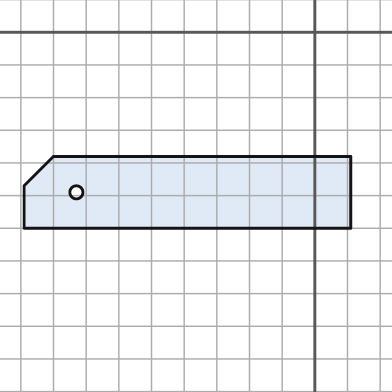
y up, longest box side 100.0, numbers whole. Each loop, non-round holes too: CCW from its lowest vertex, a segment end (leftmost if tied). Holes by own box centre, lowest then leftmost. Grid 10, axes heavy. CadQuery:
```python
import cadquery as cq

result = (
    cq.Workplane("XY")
    .moveTo(-89.0, -60.0)
    .lineTo(11.0, -60.0)
    .lineTo(11.0, -38.0)
    .lineTo(-80.0, -38.0)
    .lineTo(-89.0, -47.0)
    .close()
    .moveTo(-73.0, -49.0)
    .circle(2.0)
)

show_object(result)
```